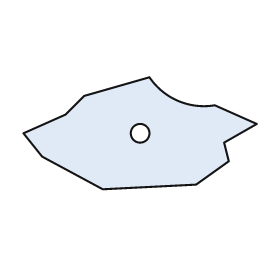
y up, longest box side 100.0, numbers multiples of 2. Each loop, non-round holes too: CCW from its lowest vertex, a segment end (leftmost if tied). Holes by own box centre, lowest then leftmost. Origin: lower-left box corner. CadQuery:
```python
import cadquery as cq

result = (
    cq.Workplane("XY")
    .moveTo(34.0, 0.0)
    .lineTo(74.0, 2.0)
    .lineTo(88.0, 12.0)
    .lineTo(86.0, 20.0)
    .lineTo(100.0, 28.0)
    .lineTo(82.0, 36.0)
    .threePointArc((66.0, 38.0), (54.0, 48.0))
    .lineTo(26.0, 40.0)
    .lineTo(18.0, 32.0)
    .lineTo(0.0, 24.0)
    .lineTo(8.0, 14.0)
    .close()
    .moveTo(50.0, 24.0)
    .circle(4.0)
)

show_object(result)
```